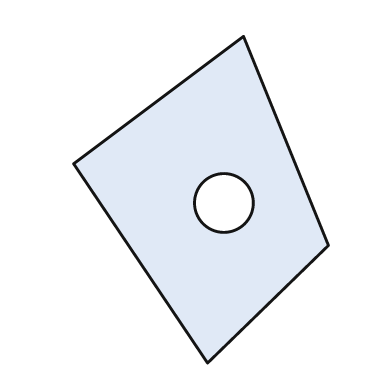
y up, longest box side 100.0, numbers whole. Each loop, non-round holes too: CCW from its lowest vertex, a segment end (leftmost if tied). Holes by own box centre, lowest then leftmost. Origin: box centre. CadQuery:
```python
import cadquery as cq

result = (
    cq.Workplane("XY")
    .moveTo(2.0, -50.0)
    .lineTo(39.0, -14.0)
    .lineTo(13.0, 50.0)
    .lineTo(-39.0, 11.0)
    .close()
    .moveTo(7.0, -1.0)
    .circle(9.0)
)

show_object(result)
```